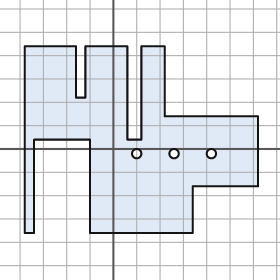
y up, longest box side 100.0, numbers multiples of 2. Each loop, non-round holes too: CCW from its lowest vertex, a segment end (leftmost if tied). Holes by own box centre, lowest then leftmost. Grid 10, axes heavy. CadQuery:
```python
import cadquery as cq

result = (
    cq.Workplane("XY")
    .moveTo(-38.0, -36.0)
    .lineTo(-34.0, -36.0)
    .lineTo(-34.0, 4.0)
    .lineTo(-10.0, 4.0)
    .lineTo(-10.0, -36.0)
    .lineTo(34.0, -36.0)
    .lineTo(34.0, -16.0)
    .lineTo(62.0, -16.0)
    .lineTo(62.0, 14.0)
    .lineTo(22.0, 14.0)
    .lineTo(22.0, 44.0)
    .lineTo(12.0, 44.0)
    .lineTo(12.0, 4.0)
    .lineTo(6.0, 4.0)
    .lineTo(6.0, 44.0)
    .lineTo(-12.0, 44.0)
    .lineTo(-12.0, 22.0)
    .lineTo(-16.0, 22.0)
    .lineTo(-16.0, 44.0)
    .lineTo(-38.0, 44.0)
    .close()
    .moveTo(10.0, -2.0)
    .circle(2.0)
    .moveTo(26.0, -2.0)
    .circle(2.0)
    .moveTo(42.0, -2.0)
    .circle(2.0)
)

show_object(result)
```